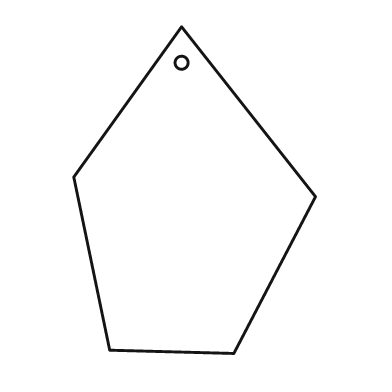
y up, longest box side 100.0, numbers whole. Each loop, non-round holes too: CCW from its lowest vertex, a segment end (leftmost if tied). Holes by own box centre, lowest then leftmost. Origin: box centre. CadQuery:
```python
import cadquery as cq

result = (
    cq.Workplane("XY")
    .moveTo(12.0, -50.0)
    .lineTo(37.0, -2.0)
    .lineTo(-4.0, 50.0)
    .lineTo(-37.0, 4.0)
    .lineTo(-26.0, -49.0)
    .close()
    .moveTo(-4.0, 39.0)
    .circle(2.0)
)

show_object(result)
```